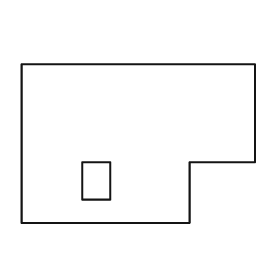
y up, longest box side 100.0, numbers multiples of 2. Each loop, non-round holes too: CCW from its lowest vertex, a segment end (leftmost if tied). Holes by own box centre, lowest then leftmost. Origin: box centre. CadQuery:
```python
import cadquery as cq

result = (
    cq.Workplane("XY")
    .moveTo(-50.0, -34.0)
    .lineTo(22.0, -34.0)
    .lineTo(22.0, -8.0)
    .lineTo(50.0, -8.0)
    .lineTo(50.0, 34.0)
    .lineTo(-50.0, 34.0)
    .close()
    .moveTo(-24.0, -24.0)
    .lineTo(-12.0, -24.0)
    .lineTo(-12.0, -8.0)
    .lineTo(-24.0, -8.0)
    .close()
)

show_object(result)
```